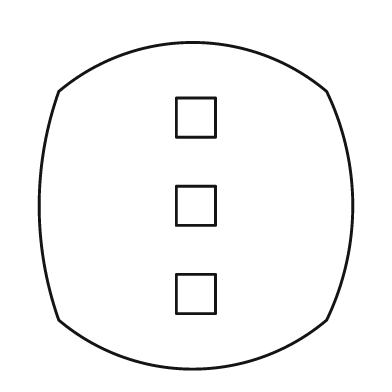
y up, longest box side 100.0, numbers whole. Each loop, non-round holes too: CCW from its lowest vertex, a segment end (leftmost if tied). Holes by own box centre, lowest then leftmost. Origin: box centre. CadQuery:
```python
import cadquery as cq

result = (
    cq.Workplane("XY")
    .moveTo(-42.0, -35.0)
    .threePointArc((-1.0, -50.0), (40.0, -35.0))
    .threePointArc((48.0, 0.0), (40.0, 35.0))
    .threePointArc((-1.0, 50.0), (-42.0, 35.0))
    .threePointArc((-48.0, 0.0), (-42.0, -35.0))
    .close()
    .moveTo(-6.0, -33.0)
    .lineTo(6.0, -33.0)
    .lineTo(6.0, -21.0)
    .lineTo(-6.0, -21.0)
    .close()
    .moveTo(-6.0, -6.0)
    .lineTo(6.0, -6.0)
    .lineTo(6.0, 6.0)
    .lineTo(-6.0, 6.0)
    .close()
    .moveTo(-6.0, 21.0)
    .lineTo(6.0, 21.0)
    .lineTo(6.0, 33.0)
    .lineTo(-6.0, 33.0)
    .close()
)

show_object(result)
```